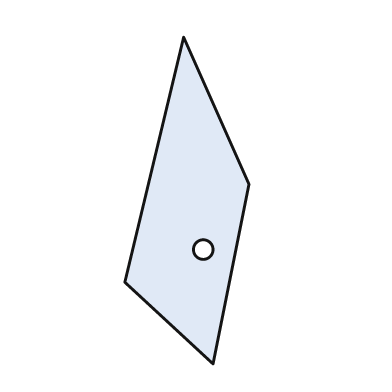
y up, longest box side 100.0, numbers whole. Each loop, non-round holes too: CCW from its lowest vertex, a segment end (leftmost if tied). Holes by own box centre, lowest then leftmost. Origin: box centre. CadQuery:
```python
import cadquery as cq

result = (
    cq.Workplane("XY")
    .moveTo(8.0, -50.0)
    .lineTo(19.0, 5.0)
    .lineTo(-1.0, 50.0)
    .lineTo(-19.0, -25.0)
    .close()
    .moveTo(5.0, -15.0)
    .circle(3.0)
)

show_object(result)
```